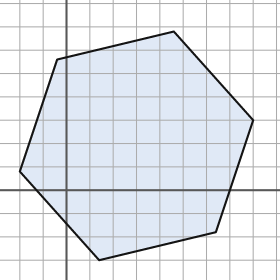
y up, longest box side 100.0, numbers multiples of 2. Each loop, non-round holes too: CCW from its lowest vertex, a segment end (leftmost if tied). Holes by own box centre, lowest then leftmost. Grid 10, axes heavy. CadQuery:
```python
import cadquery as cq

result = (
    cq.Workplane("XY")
    .moveTo(14.0, -30.0)
    .lineTo(64.0, -18.0)
    .lineTo(80.0, 30.0)
    .lineTo(46.0, 68.0)
    .lineTo(-4.0, 56.0)
    .lineTo(-20.0, 8.0)
    .close()
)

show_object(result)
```